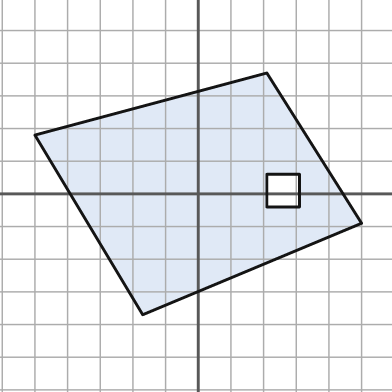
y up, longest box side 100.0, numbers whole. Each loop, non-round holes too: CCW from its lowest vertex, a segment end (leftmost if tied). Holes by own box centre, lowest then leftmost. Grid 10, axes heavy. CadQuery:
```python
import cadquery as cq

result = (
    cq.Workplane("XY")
    .moveTo(-17.0, -37.0)
    .lineTo(50.0, -9.0)
    .lineTo(21.0, 37.0)
    .lineTo(-50.0, 18.0)
    .close()
    .moveTo(21.0, -4.0)
    .lineTo(31.0, -4.0)
    .lineTo(31.0, 6.0)
    .lineTo(21.0, 6.0)
    .close()
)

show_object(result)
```